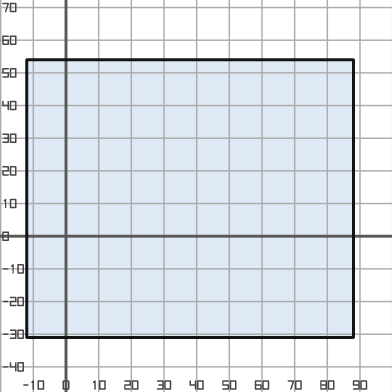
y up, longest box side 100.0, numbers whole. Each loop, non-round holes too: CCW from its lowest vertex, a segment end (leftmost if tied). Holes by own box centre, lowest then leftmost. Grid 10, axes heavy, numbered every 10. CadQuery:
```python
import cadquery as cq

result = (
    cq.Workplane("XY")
    .moveTo(-12.0, -31.0)
    .lineTo(88.0, -31.0)
    .lineTo(88.0, 54.0)
    .lineTo(-12.0, 54.0)
    .close()
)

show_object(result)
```